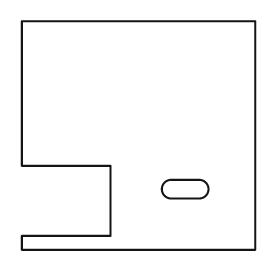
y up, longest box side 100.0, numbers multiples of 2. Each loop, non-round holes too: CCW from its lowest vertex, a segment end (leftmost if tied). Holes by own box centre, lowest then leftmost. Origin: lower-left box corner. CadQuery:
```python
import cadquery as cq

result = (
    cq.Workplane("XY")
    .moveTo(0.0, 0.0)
    .lineTo(100.0, 0.0)
    .lineTo(100.0, 98.0)
    .lineTo(0.0, 98.0)
    .lineTo(0.0, 36.0)
    .lineTo(38.0, 36.0)
    .lineTo(38.0, 6.0)
    .lineTo(0.0, 6.0)
    .close()
    .moveTo(64.0, 22.0)
    .lineTo(76.0, 22.0)
    .threePointArc((80.0, 26.0), (76.0, 30.0))
    .lineTo(64.0, 30.0)
    .threePointArc((60.0, 26.0), (64.0, 22.0))
    .close()
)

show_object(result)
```